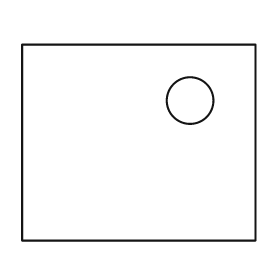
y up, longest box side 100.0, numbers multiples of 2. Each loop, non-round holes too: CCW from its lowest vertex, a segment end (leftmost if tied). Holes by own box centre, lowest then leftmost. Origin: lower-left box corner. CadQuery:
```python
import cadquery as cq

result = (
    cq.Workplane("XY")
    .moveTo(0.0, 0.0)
    .lineTo(100.0, 0.0)
    .lineTo(100.0, 84.0)
    .lineTo(0.0, 84.0)
    .close()
    .moveTo(72.0, 60.0)
    .circle(10.0)
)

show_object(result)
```